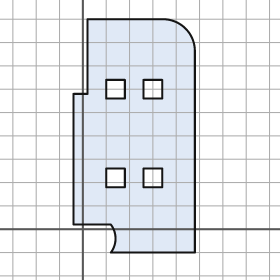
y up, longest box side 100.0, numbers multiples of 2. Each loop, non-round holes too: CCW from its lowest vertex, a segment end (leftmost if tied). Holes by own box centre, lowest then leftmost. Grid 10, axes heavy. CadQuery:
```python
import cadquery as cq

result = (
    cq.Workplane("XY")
    .moveTo(12.0, -10.0)
    .lineTo(48.0, -10.0)
    .lineTo(48.0, 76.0)
    .threePointArc((44.0, 86.0), (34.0, 90.0))
    .lineTo(2.0, 90.0)
    .lineTo(2.0, 58.0)
    .lineTo(-4.0, 58.0)
    .lineTo(-4.0, 2.0)
    .lineTo(12.0, 2.0)
    .threePointArc((14.0, -4.0), (12.0, -10.0))
    .close()
    .moveTo(10.0, 18.0)
    .lineTo(18.0, 18.0)
    .lineTo(18.0, 26.0)
    .lineTo(10.0, 26.0)
    .close()
    .moveTo(26.0, 18.0)
    .lineTo(34.0, 18.0)
    .lineTo(34.0, 26.0)
    .lineTo(26.0, 26.0)
    .close()
    .moveTo(10.0, 56.0)
    .lineTo(18.0, 56.0)
    .lineTo(18.0, 64.0)
    .lineTo(10.0, 64.0)
    .close()
    .moveTo(26.0, 56.0)
    .lineTo(34.0, 56.0)
    .lineTo(34.0, 64.0)
    .lineTo(26.0, 64.0)
    .close()
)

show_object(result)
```